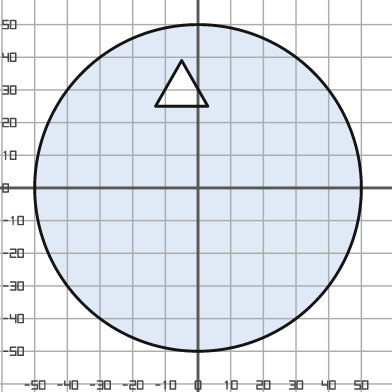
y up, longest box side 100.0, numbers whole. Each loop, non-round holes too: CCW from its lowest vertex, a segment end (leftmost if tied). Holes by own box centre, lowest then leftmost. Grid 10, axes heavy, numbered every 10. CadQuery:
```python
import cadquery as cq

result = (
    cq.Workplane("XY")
    .moveTo(0.0, 0.0)
    .circle(50.0)
    .moveTo(-13.0, 25.0)
    .lineTo(3.0, 25.0)
    .lineTo(-5.0, 39.0)
    .close()
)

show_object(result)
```